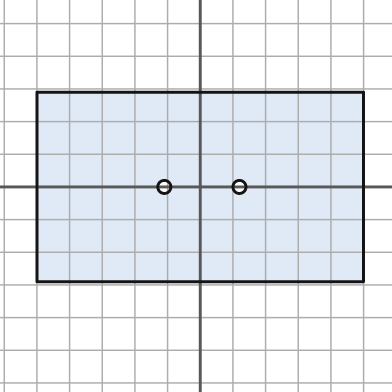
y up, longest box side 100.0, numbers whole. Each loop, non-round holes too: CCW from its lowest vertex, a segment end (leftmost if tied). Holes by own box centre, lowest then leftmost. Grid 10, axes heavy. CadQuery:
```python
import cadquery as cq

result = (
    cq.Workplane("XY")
    .moveTo(-50.0, -29.0)
    .lineTo(50.0, -29.0)
    .lineTo(50.0, 29.0)
    .lineTo(-50.0, 29.0)
    .close()
    .moveTo(-11.0, 0.0)
    .circle(2.0)
    .moveTo(12.0, 0.0)
    .circle(2.0)
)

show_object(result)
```